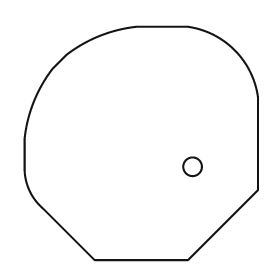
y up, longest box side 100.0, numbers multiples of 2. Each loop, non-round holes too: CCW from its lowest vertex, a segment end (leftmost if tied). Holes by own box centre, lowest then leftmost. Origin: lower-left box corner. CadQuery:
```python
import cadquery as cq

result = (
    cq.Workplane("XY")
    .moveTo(30.0, 0.0)
    .lineTo(70.0, 0.0)
    .lineTo(100.0, 30.0)
    .lineTo(100.0, 70.0)
    .threePointArc((90.0, 90.0), (70.0, 100.0))
    .lineTo(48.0, 100.0)
    .threePointArc((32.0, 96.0), (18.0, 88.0))
    .lineTo(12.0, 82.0)
    .threePointArc((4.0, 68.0), (0.0, 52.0))
    .lineTo(0.0, 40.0)
    .threePointArc((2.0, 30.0), (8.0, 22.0))
    .close()
    .moveTo(72.0, 40.0)
    .circle(4.0)
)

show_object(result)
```